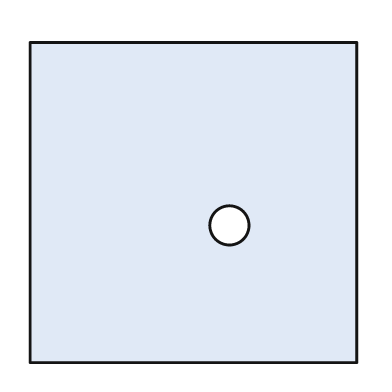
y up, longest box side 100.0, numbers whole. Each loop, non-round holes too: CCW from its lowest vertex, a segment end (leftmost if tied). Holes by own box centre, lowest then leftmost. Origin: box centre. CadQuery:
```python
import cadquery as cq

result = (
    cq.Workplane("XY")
    .moveTo(-50.0, -49.0)
    .lineTo(50.0, -49.0)
    .lineTo(50.0, 49.0)
    .lineTo(-50.0, 49.0)
    .close()
    .moveTo(11.0, -7.0)
    .circle(6.0)
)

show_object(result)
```